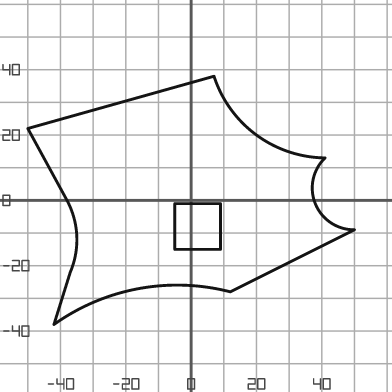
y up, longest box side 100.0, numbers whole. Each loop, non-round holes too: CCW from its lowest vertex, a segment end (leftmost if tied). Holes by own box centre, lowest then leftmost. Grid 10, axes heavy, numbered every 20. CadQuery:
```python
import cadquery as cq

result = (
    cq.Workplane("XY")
    .moveTo(-42.0, -38.0)
    .threePointArc((-16.0, -27.0), (12.0, -28.0))
    .lineTo(50.0, -9.0)
    .threePointArc((38.0, -1.0), (41.0, 13.0))
    .threePointArc((20.0, 20.0), (7.0, 38.0))
    .lineTo(-50.0, 22.0)
    .lineTo(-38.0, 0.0)
    .threePointArc((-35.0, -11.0), (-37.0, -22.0))
    .close()
    .moveTo(-5.0, -15.0)
    .lineTo(9.0, -15.0)
    .lineTo(9.0, -1.0)
    .lineTo(-5.0, -1.0)
    .close()
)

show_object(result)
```